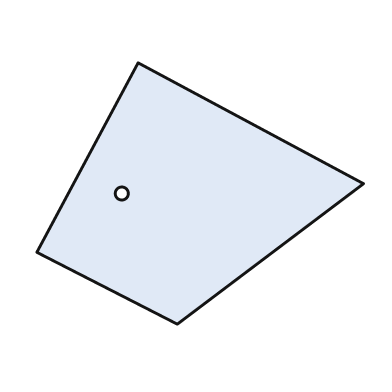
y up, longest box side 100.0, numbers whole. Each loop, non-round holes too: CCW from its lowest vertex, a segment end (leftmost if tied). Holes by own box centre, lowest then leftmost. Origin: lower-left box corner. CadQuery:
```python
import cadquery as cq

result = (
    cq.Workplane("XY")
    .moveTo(43.0, 0.0)
    .lineTo(100.0, 43.0)
    .lineTo(31.0, 80.0)
    .lineTo(0.0, 22.0)
    .close()
    .moveTo(26.0, 40.0)
    .circle(2.0)
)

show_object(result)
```